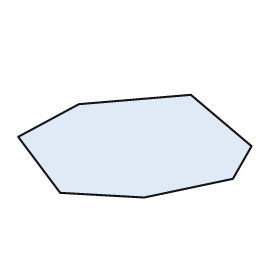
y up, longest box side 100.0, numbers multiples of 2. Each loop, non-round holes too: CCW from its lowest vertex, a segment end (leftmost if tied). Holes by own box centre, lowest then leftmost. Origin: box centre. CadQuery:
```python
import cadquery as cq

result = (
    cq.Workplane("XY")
    .moveTo(4.0, -22.0)
    .lineTo(42.0, -14.0)
    .lineTo(50.0, 0.0)
    .lineTo(24.0, 22.0)
    .lineTo(-24.0, 18.0)
    .lineTo(-50.0, 4.0)
    .lineTo(-32.0, -20.0)
    .close()
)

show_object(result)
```